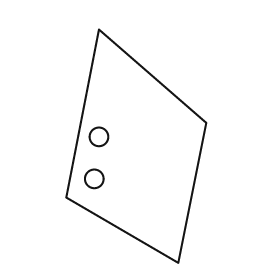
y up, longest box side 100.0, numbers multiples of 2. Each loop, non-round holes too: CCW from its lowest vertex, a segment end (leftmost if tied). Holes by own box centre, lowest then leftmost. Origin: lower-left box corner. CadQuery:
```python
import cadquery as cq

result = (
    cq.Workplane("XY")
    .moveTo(48.0, 0.0)
    .lineTo(60.0, 60.0)
    .lineTo(14.0, 100.0)
    .lineTo(0.0, 28.0)
    .close()
    .moveTo(12.0, 36.0)
    .circle(4.0)
    .moveTo(14.0, 54.0)
    .circle(4.0)
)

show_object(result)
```